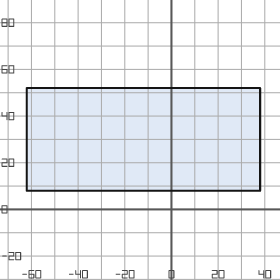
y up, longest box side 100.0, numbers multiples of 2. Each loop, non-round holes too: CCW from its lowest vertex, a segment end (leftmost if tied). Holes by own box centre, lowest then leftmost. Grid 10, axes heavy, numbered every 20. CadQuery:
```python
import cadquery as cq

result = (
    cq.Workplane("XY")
    .moveTo(-62.0, 8.0)
    .lineTo(38.0, 8.0)
    .lineTo(38.0, 52.0)
    .lineTo(-62.0, 52.0)
    .close()
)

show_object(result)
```